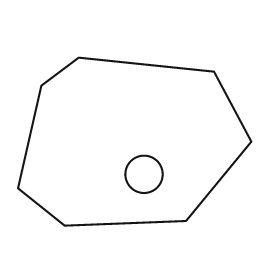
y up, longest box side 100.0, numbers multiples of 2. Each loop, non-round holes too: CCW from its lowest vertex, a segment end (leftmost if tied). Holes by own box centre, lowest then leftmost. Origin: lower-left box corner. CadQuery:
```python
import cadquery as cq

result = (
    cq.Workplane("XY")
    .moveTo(20.0, 0.0)
    .lineTo(72.0, 2.0)
    .lineTo(100.0, 36.0)
    .lineTo(84.0, 66.0)
    .lineTo(26.0, 72.0)
    .lineTo(10.0, 60.0)
    .lineTo(0.0, 16.0)
    .close()
    .moveTo(54.0, 22.0)
    .circle(8.0)
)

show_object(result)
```